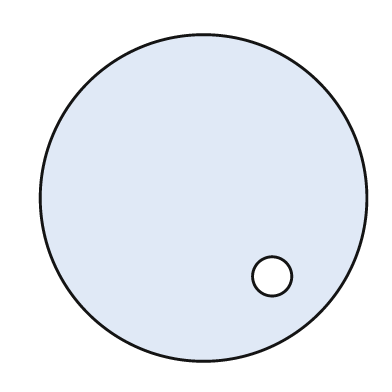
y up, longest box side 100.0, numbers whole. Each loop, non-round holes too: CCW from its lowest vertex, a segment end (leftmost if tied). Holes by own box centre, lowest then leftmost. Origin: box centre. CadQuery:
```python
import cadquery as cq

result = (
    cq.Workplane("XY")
    .moveTo(0.0, 0.0)
    .circle(50.0)
    .moveTo(21.0, -24.0)
    .circle(6.0)
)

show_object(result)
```